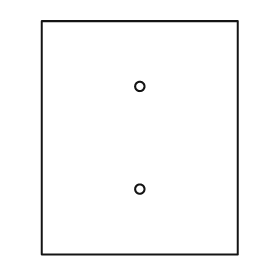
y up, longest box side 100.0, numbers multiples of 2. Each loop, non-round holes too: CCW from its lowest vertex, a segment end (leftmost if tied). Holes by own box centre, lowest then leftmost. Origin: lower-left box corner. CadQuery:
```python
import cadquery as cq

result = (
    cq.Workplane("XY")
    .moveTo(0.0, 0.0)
    .lineTo(84.0, 0.0)
    .lineTo(84.0, 100.0)
    .lineTo(0.0, 100.0)
    .close()
    .moveTo(42.0, 28.0)
    .circle(2.0)
    .moveTo(42.0, 72.0)
    .circle(2.0)
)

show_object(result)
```